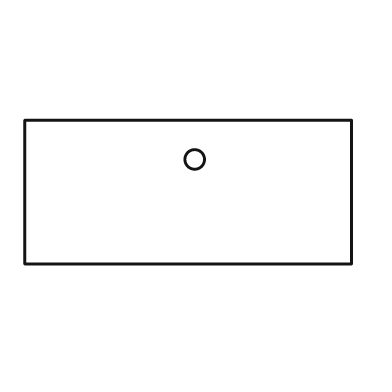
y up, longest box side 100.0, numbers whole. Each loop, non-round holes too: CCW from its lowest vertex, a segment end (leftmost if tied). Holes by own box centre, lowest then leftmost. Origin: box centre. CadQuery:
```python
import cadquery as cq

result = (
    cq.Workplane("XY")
    .moveTo(-50.0, -22.0)
    .lineTo(50.0, -22.0)
    .lineTo(50.0, 22.0)
    .lineTo(-50.0, 22.0)
    .close()
    .moveTo(2.0, 10.0)
    .circle(3.0)
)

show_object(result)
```